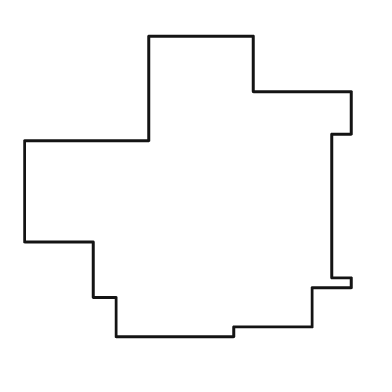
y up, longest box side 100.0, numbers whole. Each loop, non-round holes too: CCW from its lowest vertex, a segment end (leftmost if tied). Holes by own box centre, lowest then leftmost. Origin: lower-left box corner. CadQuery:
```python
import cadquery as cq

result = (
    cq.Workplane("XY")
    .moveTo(28.0, 0.0)
    .lineTo(64.0, 0.0)
    .lineTo(64.0, 3.0)
    .lineTo(88.0, 3.0)
    .lineTo(88.0, 15.0)
    .lineTo(100.0, 15.0)
    .lineTo(100.0, 18.0)
    .lineTo(94.0, 18.0)
    .lineTo(94.0, 62.0)
    .lineTo(100.0, 62.0)
    .lineTo(100.0, 75.0)
    .lineTo(70.0, 75.0)
    .lineTo(70.0, 92.0)
    .lineTo(38.0, 92.0)
    .lineTo(38.0, 60.0)
    .lineTo(0.0, 60.0)
    .lineTo(0.0, 29.0)
    .lineTo(21.0, 29.0)
    .lineTo(21.0, 12.0)
    .lineTo(28.0, 12.0)
    .close()
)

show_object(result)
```